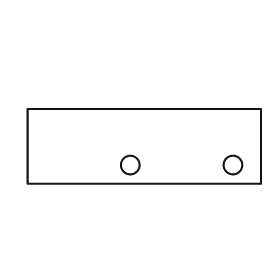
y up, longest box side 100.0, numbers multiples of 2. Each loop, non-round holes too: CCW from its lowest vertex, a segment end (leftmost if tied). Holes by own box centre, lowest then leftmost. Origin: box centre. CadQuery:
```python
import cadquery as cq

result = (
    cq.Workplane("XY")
    .moveTo(-50.0, -16.0)
    .lineTo(50.0, -16.0)
    .lineTo(50.0, 16.0)
    .lineTo(-50.0, 16.0)
    .close()
    .moveTo(-6.0, -8.0)
    .circle(4.0)
    .moveTo(38.0, -8.0)
    .circle(4.0)
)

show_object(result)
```